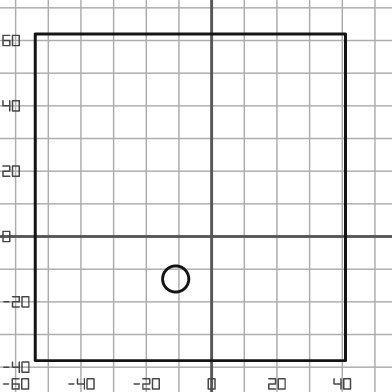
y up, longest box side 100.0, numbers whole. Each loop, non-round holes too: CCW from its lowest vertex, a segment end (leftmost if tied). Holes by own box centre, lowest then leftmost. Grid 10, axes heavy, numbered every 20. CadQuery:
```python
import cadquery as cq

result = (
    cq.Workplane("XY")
    .moveTo(-54.0, -38.0)
    .lineTo(41.0, -38.0)
    .lineTo(41.0, 62.0)
    .lineTo(-54.0, 62.0)
    .close()
    .moveTo(-11.0, -13.0)
    .circle(4.0)
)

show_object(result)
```